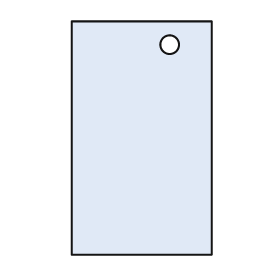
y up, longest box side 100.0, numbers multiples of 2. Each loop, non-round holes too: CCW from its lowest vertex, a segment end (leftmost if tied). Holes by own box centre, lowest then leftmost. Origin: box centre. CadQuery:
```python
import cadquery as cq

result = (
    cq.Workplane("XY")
    .moveTo(-30.0, -50.0)
    .lineTo(30.0, -50.0)
    .lineTo(30.0, 50.0)
    .lineTo(-30.0, 50.0)
    .close()
    .moveTo(12.0, 40.0)
    .circle(4.0)
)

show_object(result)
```